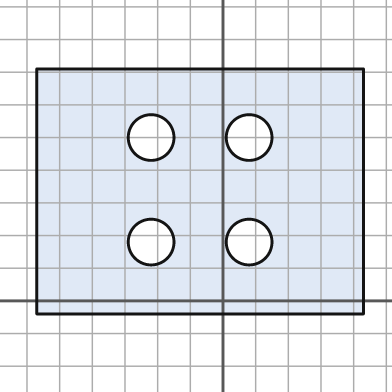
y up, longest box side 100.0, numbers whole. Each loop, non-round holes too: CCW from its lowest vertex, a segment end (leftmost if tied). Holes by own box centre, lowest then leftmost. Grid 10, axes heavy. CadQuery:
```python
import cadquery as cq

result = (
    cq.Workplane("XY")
    .moveTo(-57.0, -4.0)
    .lineTo(43.0, -4.0)
    .lineTo(43.0, 71.0)
    .lineTo(-57.0, 71.0)
    .close()
    .moveTo(-22.0, 18.0)
    .circle(7.0)
    .moveTo(8.0, 18.0)
    .circle(7.0)
    .moveTo(-22.0, 50.0)
    .circle(7.0)
    .moveTo(8.0, 50.0)
    .circle(7.0)
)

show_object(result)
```